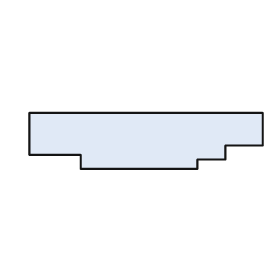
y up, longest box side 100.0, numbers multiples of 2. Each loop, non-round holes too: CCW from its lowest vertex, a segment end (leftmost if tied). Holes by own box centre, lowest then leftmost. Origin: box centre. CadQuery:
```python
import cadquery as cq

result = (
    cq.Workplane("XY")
    .moveTo(-28.0, -12.0)
    .lineTo(22.0, -12.0)
    .lineTo(22.0, -8.0)
    .lineTo(34.0, -8.0)
    .lineTo(34.0, -2.0)
    .lineTo(50.0, -2.0)
    .lineTo(50.0, 12.0)
    .lineTo(-50.0, 12.0)
    .lineTo(-50.0, -6.0)
    .lineTo(-28.0, -6.0)
    .close()
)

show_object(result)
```